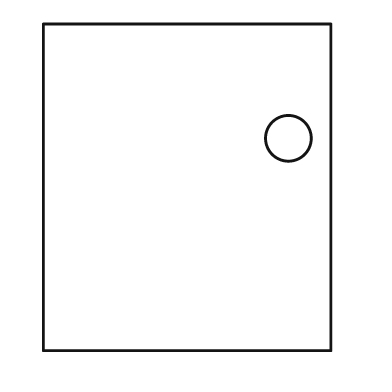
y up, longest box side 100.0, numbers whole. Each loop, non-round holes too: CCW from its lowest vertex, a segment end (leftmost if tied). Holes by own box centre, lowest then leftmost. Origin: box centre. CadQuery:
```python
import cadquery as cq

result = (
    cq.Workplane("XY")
    .moveTo(-44.0, -50.0)
    .lineTo(44.0, -50.0)
    .lineTo(44.0, 50.0)
    .lineTo(-44.0, 50.0)
    .close()
    .moveTo(31.0, 15.0)
    .circle(7.0)
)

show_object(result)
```